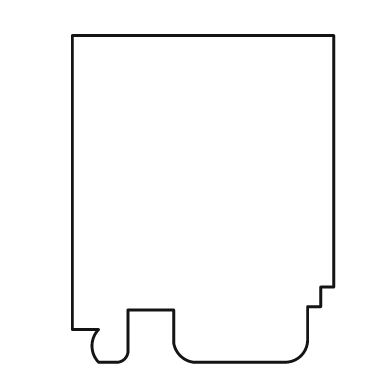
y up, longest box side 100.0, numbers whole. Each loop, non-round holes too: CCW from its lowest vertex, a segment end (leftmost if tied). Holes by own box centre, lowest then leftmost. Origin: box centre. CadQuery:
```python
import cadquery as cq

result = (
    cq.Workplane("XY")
    .moveTo(-32.0, -50.0)
    .lineTo(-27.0, -50.0)
    .threePointArc((-24.0, -49.0), (-23.0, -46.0))
    .lineTo(-23.0, -34.0)
    .lineTo(-9.0, -34.0)
    .lineTo(-9.0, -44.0)
    .threePointArc((-7.0, -48.0), (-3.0, -50.0))
    .lineTo(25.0, -50.0)
    .threePointArc((30.0, -48.0), (32.0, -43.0))
    .lineTo(32.0, -33.0)
    .lineTo(36.0, -33.0)
    .lineTo(36.0, -27.0)
    .lineTo(40.0, -27.0)
    .lineTo(40.0, 50.0)
    .lineTo(-40.0, 50.0)
    .lineTo(-40.0, -40.0)
    .lineTo(-32.0, -40.0)
    .threePointArc((-34.0, -45.0), (-32.0, -50.0))
    .close()
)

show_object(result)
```